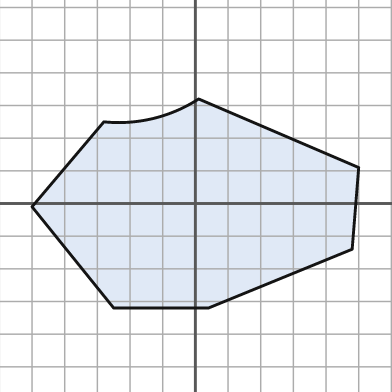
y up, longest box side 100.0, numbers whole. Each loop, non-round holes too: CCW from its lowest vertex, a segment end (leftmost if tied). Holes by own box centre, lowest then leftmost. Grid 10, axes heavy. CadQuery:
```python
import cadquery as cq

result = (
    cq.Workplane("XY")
    .moveTo(-25.0, -32.0)
    .lineTo(4.0, -32.0)
    .lineTo(48.0, -14.0)
    .lineTo(50.0, 11.0)
    .lineTo(1.0, 32.0)
    .threePointArc((-13.0, 26.0), (-28.0, 25.0))
    .lineTo(-50.0, -1.0)
    .close()
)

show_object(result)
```